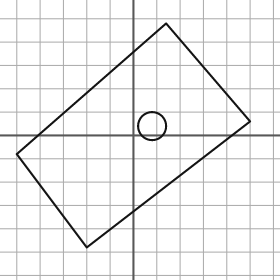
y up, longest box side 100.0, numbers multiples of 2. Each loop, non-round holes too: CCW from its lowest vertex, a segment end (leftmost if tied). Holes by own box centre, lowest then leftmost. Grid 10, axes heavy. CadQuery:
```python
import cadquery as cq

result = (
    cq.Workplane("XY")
    .moveTo(-20.0, -48.0)
    .lineTo(50.0, 6.0)
    .lineTo(14.0, 48.0)
    .lineTo(-50.0, -8.0)
    .close()
    .moveTo(8.0, 4.0)
    .circle(6.0)
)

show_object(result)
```